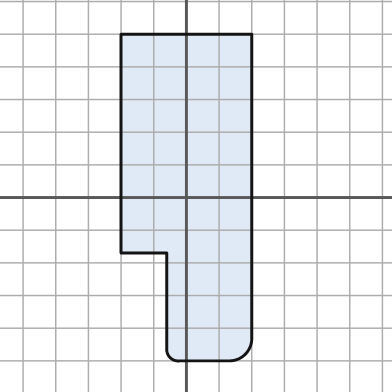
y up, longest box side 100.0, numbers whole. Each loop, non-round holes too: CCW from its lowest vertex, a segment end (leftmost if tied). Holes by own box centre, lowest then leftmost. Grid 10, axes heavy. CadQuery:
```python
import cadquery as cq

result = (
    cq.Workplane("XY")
    .moveTo(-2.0, -50.0)
    .lineTo(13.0, -50.0)
    .threePointArc((18.0, -48.0), (20.0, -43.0))
    .lineTo(20.0, 50.0)
    .lineTo(-20.0, 50.0)
    .lineTo(-20.0, -17.0)
    .lineTo(-6.0, -17.0)
    .lineTo(-6.0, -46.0)
    .threePointArc((-5.0, -49.0), (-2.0, -50.0))
    .close()
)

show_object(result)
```